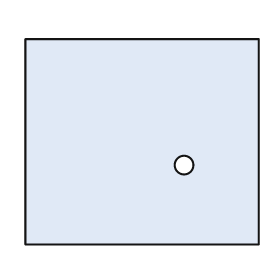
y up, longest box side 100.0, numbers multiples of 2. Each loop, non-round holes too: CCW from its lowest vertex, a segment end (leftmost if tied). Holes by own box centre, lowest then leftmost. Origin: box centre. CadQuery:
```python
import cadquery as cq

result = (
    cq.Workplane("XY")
    .moveTo(-50.0, -44.0)
    .lineTo(50.0, -44.0)
    .lineTo(50.0, 44.0)
    .lineTo(-50.0, 44.0)
    .close()
    .moveTo(18.0, -10.0)
    .circle(4.0)
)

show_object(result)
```